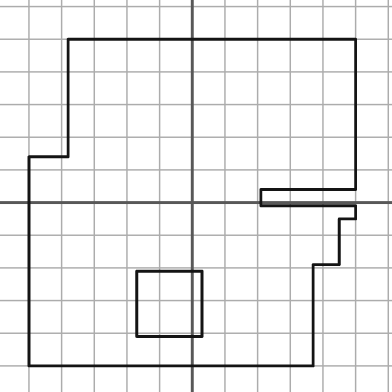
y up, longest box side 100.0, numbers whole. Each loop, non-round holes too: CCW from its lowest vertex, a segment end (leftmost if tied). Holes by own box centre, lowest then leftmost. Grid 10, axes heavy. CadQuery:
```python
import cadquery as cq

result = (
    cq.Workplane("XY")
    .moveTo(-50.0, -50.0)
    .lineTo(37.0, -50.0)
    .lineTo(37.0, -19.0)
    .lineTo(45.0, -19.0)
    .lineTo(45.0, -5.0)
    .lineTo(50.0, -5.0)
    .lineTo(50.0, -1.0)
    .lineTo(21.0, -1.0)
    .lineTo(21.0, 4.0)
    .lineTo(50.0, 4.0)
    .lineTo(50.0, 50.0)
    .lineTo(-38.0, 50.0)
    .lineTo(-38.0, 14.0)
    .lineTo(-50.0, 14.0)
    .close()
    .moveTo(-17.0, -41.0)
    .lineTo(3.0, -41.0)
    .lineTo(3.0, -21.0)
    .lineTo(-17.0, -21.0)
    .close()
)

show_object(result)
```